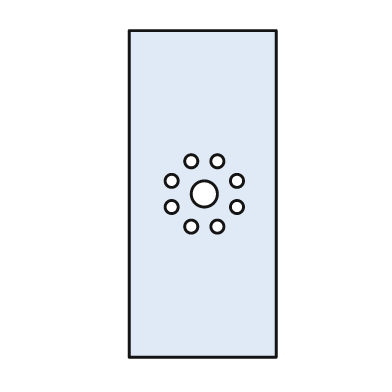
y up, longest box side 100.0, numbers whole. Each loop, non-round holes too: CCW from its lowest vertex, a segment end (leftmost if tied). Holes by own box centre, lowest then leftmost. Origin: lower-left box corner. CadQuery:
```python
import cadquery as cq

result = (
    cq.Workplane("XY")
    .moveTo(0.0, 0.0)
    .lineTo(45.0, 0.0)
    .lineTo(45.0, 100.0)
    .lineTo(0.0, 100.0)
    .close()
    .moveTo(19.0, 40.0)
    .circle(2.0)
    .moveTo(27.0, 40.0)
    .circle(2.0)
    .moveTo(13.0, 46.0)
    .circle(2.0)
    .moveTo(33.0, 46.0)
    .circle(2.0)
    .moveTo(23.0, 50.0)
    .circle(4.0)
    .moveTo(13.0, 54.0)
    .circle(2.0)
    .moveTo(33.0, 54.0)
    .circle(2.0)
    .moveTo(19.0, 60.0)
    .circle(2.0)
    .moveTo(27.0, 60.0)
    .circle(2.0)
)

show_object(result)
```